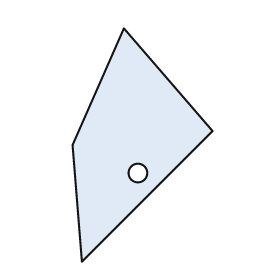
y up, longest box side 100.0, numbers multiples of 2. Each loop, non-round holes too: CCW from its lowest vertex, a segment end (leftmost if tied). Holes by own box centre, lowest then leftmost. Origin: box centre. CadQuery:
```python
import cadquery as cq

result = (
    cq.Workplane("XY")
    .moveTo(-26.0, -50.0)
    .lineTo(30.0, 6.0)
    .lineTo(-8.0, 50.0)
    .lineTo(-30.0, 0.0)
    .close()
    .moveTo(-2.0, -12.0)
    .circle(4.0)
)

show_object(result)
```